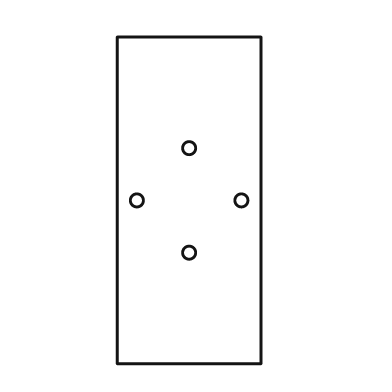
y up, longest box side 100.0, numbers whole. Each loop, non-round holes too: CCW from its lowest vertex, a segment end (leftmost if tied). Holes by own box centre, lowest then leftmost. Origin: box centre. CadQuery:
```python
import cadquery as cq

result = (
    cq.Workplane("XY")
    .moveTo(-22.0, -50.0)
    .lineTo(22.0, -50.0)
    .lineTo(22.0, 50.0)
    .lineTo(-22.0, 50.0)
    .close()
    .moveTo(0.0, -16.0)
    .circle(2.0)
    .moveTo(-16.0, 0.0)
    .circle(2.0)
    .moveTo(16.0, 0.0)
    .circle(2.0)
    .moveTo(0.0, 16.0)
    .circle(2.0)
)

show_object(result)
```